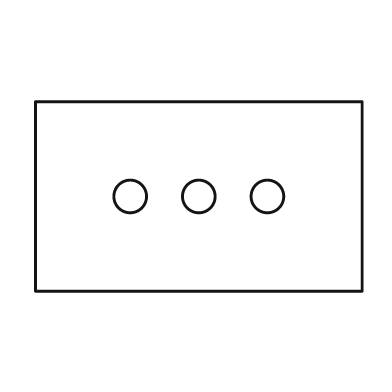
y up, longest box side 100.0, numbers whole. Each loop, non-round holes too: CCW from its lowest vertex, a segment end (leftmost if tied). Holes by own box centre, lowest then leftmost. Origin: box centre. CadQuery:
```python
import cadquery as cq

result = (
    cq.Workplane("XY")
    .moveTo(-50.0, -29.0)
    .lineTo(50.0, -29.0)
    .lineTo(50.0, 29.0)
    .lineTo(-50.0, 29.0)
    .close()
    .moveTo(-21.0, 0.0)
    .circle(5.0)
    .moveTo(0.0, 0.0)
    .circle(5.0)
    .moveTo(21.0, 0.0)
    .circle(5.0)
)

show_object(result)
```